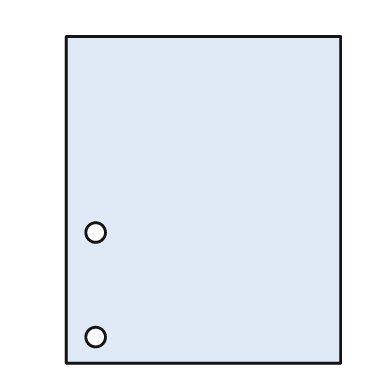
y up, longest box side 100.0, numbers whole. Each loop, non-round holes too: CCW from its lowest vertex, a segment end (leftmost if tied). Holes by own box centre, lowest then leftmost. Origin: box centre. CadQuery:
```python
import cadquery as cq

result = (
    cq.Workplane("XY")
    .moveTo(-42.0, -50.0)
    .lineTo(42.0, -50.0)
    .lineTo(42.0, 50.0)
    .lineTo(-42.0, 50.0)
    .close()
    .moveTo(-33.0, -42.0)
    .circle(3.0)
    .moveTo(-33.0, -10.0)
    .circle(3.0)
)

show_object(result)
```